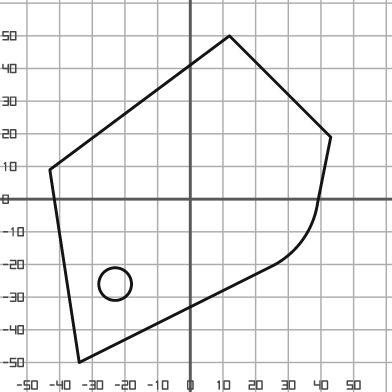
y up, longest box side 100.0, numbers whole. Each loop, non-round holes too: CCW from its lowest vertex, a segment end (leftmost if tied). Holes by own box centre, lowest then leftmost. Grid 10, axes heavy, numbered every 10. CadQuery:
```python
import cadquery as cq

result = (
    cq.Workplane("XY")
    .moveTo(-34.0, -50.0)
    .lineTo(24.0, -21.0)
    .threePointArc((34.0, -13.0), (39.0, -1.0))
    .lineTo(43.0, 19.0)
    .lineTo(12.0, 50.0)
    .lineTo(-43.0, 9.0)
    .close()
    .moveTo(-23.0, -26.0)
    .circle(5.0)
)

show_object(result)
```